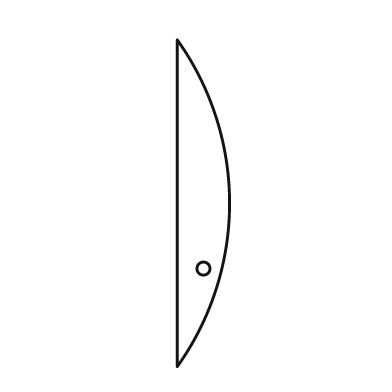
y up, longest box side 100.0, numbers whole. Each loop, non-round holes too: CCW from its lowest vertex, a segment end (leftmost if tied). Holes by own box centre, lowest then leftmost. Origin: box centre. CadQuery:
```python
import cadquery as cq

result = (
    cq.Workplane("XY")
    .moveTo(-8.0, -50.0)
    .threePointArc((8.0, 0.0), (-8.0, 50.0))
    .close()
    .moveTo(0.0, -20.0)
    .circle(2.0)
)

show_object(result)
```